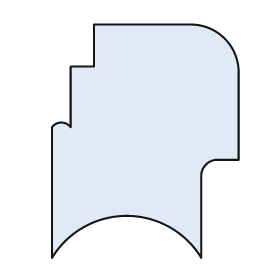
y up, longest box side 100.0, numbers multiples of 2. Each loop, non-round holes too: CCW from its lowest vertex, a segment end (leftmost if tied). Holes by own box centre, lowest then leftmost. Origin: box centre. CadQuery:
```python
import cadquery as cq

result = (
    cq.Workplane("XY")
    .moveTo(-40.0, -50.0)
    .threePointArc((-8.0, -32.0), (24.0, -50.0))
    .lineTo(24.0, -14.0)
    .threePointArc((26.0, -10.0), (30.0, -8.0))
    .lineTo(40.0, -8.0)
    .lineTo(40.0, 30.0)
    .threePointArc((34.0, 44.0), (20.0, 50.0))
    .lineTo(-22.0, 50.0)
    .lineTo(-22.0, 32.0)
    .lineTo(-32.0, 32.0)
    .lineTo(-32.0, 6.0)
    .threePointArc((-36.0, 8.0), (-40.0, 6.0))
    .close()
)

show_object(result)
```